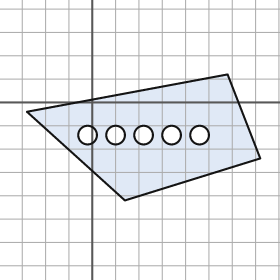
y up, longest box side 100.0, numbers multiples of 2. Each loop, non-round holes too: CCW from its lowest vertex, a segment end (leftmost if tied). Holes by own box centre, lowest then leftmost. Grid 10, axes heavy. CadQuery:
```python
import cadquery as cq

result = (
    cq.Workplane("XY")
    .moveTo(14.0, -42.0)
    .lineTo(72.0, -24.0)
    .lineTo(58.0, 12.0)
    .lineTo(-28.0, -4.0)
    .close()
    .moveTo(-2.0, -14.0)
    .circle(4.0)
    .moveTo(10.0, -14.0)
    .circle(4.0)
    .moveTo(22.0, -14.0)
    .circle(4.0)
    .moveTo(34.0, -14.0)
    .circle(4.0)
    .moveTo(46.0, -14.0)
    .circle(4.0)
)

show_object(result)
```